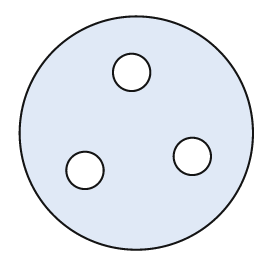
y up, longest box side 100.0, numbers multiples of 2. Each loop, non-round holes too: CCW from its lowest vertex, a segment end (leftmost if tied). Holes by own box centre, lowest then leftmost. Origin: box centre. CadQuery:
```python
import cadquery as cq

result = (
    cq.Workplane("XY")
    .moveTo(0.0, 0.0)
    .circle(50.0)
    .moveTo(-22.0, -16.0)
    .circle(8.0)
    .moveTo(24.0, -10.0)
    .circle(8.0)
    .moveTo(-2.0, 26.0)
    .circle(8.0)
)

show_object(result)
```